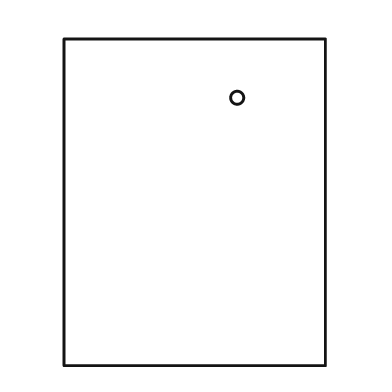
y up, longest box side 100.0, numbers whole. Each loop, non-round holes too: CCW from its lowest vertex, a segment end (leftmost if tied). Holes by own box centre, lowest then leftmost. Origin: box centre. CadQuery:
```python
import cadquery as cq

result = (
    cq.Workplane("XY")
    .moveTo(-40.0, -50.0)
    .lineTo(40.0, -50.0)
    .lineTo(40.0, 50.0)
    .lineTo(-40.0, 50.0)
    .close()
    .moveTo(13.0, 32.0)
    .circle(2.0)
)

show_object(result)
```